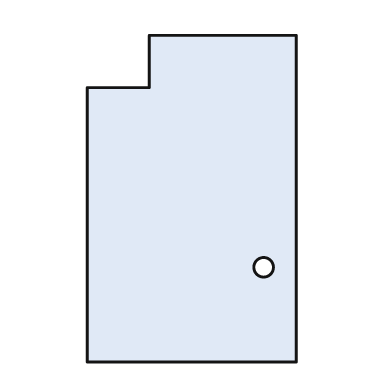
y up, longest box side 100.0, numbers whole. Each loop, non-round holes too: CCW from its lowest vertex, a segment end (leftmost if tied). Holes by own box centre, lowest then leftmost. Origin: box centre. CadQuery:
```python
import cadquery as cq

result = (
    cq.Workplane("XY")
    .moveTo(-32.0, -50.0)
    .lineTo(32.0, -50.0)
    .lineTo(32.0, 50.0)
    .lineTo(-13.0, 50.0)
    .lineTo(-13.0, 34.0)
    .lineTo(-32.0, 34.0)
    .close()
    .moveTo(22.0, -21.0)
    .circle(3.0)
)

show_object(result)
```